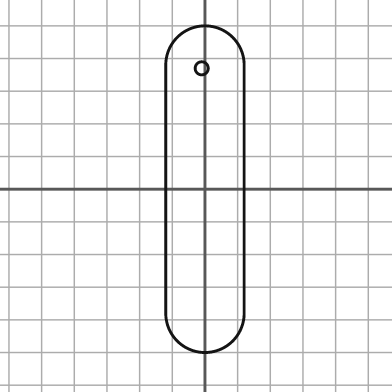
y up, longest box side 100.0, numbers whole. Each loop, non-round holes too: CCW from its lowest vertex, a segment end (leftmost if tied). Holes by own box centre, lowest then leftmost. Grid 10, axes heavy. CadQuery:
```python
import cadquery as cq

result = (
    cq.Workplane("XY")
    .moveTo(-12.0, -38.0)
    .threePointArc((0.0, -50.0), (12.0, -38.0))
    .lineTo(12.0, 38.0)
    .threePointArc((0.0, 50.0), (-12.0, 38.0))
    .close()
    .moveTo(-1.0, 37.0)
    .circle(2.0)
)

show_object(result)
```